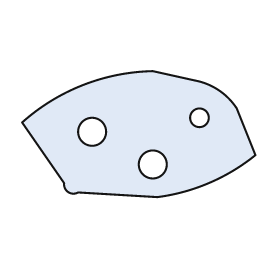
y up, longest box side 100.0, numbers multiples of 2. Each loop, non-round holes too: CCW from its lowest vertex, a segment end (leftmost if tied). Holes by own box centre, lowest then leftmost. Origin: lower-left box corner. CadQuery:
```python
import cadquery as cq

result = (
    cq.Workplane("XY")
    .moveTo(58.0, 0.0)
    .threePointArc((80.0, 6.0), (100.0, 18.0))
    .lineTo(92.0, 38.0)
    .threePointArc((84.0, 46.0), (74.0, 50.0))
    .lineTo(56.0, 54.0)
    .threePointArc((26.0, 48.0), (0.0, 32.0))
    .lineTo(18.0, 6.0)
    .threePointArc((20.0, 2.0), (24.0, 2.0))
    .close()
    .moveTo(56.0, 14.0)
    .circle(6.0)
    .moveTo(30.0, 28.0)
    .circle(6.0)
    .moveTo(76.0, 34.0)
    .circle(4.0)
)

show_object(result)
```